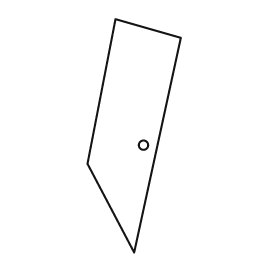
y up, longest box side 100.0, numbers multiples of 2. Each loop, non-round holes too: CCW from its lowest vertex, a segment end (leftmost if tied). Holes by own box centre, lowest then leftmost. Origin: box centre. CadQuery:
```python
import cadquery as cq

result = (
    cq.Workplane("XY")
    .moveTo(0.0, -50.0)
    .lineTo(20.0, 42.0)
    .lineTo(-8.0, 50.0)
    .lineTo(-20.0, -12.0)
    .close()
    .moveTo(4.0, -4.0)
    .circle(2.0)
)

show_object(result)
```